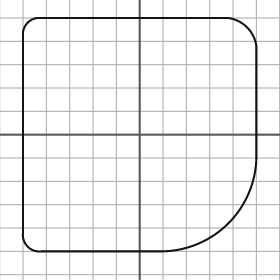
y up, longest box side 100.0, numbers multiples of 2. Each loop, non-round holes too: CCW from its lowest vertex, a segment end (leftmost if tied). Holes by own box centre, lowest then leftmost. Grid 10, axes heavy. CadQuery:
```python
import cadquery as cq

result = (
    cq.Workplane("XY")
    .moveTo(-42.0, -50.0)
    .lineTo(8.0, -50.0)
    .threePointArc((38.0, -38.0), (50.0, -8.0))
    .lineTo(50.0, 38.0)
    .threePointArc((46.0, 46.0), (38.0, 50.0))
    .lineTo(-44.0, 50.0)
    .threePointArc((-48.0, 48.0), (-50.0, 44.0))
    .lineTo(-50.0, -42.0)
    .threePointArc((-48.0, -48.0), (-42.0, -50.0))
    .close()
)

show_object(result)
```